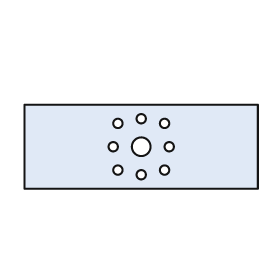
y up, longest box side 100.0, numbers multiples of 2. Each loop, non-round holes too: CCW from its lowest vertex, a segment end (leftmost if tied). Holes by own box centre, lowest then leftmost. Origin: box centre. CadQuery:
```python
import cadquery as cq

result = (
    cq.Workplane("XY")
    .moveTo(-50.0, -18.0)
    .lineTo(50.0, -18.0)
    .lineTo(50.0, 18.0)
    .lineTo(-50.0, 18.0)
    .close()
    .moveTo(0.0, -12.0)
    .circle(2.0)
    .moveTo(-10.0, -10.0)
    .circle(2.0)
    .moveTo(10.0, -10.0)
    .circle(2.0)
    .moveTo(-12.0, 0.0)
    .circle(2.0)
    .moveTo(0.0, 0.0)
    .circle(4.0)
    .moveTo(12.0, 0.0)
    .circle(2.0)
    .moveTo(-10.0, 10.0)
    .circle(2.0)
    .moveTo(10.0, 10.0)
    .circle(2.0)
    .moveTo(0.0, 12.0)
    .circle(2.0)
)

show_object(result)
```